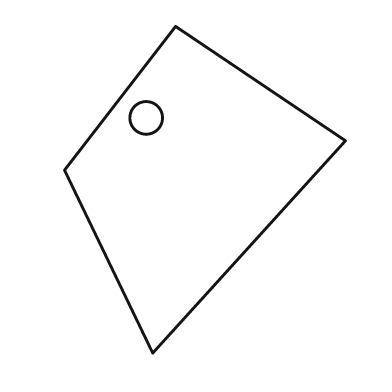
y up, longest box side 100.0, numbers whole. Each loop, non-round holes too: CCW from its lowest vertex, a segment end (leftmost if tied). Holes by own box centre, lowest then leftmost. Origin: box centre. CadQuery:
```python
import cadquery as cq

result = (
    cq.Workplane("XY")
    .moveTo(-16.0, -50.0)
    .lineTo(43.0, 15.0)
    .lineTo(-9.0, 50.0)
    .lineTo(-43.0, 6.0)
    .close()
    .moveTo(-18.0, 22.0)
    .circle(5.0)
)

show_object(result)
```